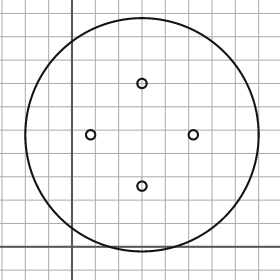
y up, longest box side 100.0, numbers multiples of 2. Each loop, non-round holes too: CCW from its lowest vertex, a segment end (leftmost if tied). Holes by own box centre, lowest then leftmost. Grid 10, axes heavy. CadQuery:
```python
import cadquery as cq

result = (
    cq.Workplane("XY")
    .moveTo(30.0, 48.0)
    .circle(50.0)
    .moveTo(30.0, 26.0)
    .circle(2.0)
    .moveTo(8.0, 48.0)
    .circle(2.0)
    .moveTo(52.0, 48.0)
    .circle(2.0)
    .moveTo(30.0, 70.0)
    .circle(2.0)
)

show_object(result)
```